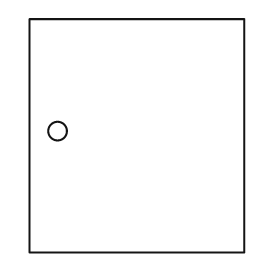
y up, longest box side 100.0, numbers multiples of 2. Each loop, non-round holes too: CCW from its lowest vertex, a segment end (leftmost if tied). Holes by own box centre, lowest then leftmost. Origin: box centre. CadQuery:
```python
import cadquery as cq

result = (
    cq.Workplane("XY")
    .moveTo(-46.0, -50.0)
    .lineTo(46.0, -50.0)
    .lineTo(46.0, 50.0)
    .lineTo(-46.0, 50.0)
    .close()
    .moveTo(-34.0, 2.0)
    .circle(4.0)
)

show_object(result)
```